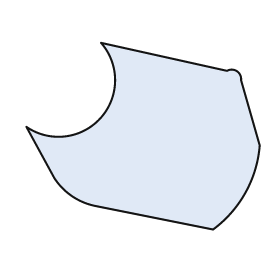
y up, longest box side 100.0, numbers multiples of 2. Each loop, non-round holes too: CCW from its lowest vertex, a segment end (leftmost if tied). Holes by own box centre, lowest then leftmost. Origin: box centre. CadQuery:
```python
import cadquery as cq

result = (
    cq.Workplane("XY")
    .moveTo(30.0, -40.0)
    .threePointArc((44.0, -24.0), (50.0, -4.0))
    .lineTo(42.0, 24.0)
    .threePointArc((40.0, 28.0), (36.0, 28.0))
    .lineTo(-18.0, 40.0)
    .threePointArc((-18.0, 8.0), (-50.0, 4.0))
    .lineTo(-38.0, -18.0)
    .threePointArc((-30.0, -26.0), (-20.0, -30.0))
    .close()
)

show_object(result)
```